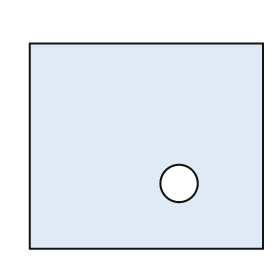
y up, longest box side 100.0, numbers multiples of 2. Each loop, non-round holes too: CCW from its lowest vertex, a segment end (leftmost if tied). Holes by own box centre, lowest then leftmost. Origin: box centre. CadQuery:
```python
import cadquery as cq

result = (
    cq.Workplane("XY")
    .moveTo(-50.0, -44.0)
    .lineTo(50.0, -44.0)
    .lineTo(50.0, 44.0)
    .lineTo(-50.0, 44.0)
    .close()
    .moveTo(14.0, -16.0)
    .circle(8.0)
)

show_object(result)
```